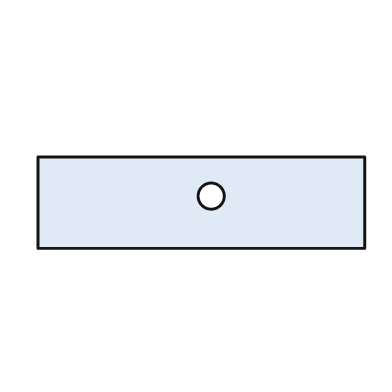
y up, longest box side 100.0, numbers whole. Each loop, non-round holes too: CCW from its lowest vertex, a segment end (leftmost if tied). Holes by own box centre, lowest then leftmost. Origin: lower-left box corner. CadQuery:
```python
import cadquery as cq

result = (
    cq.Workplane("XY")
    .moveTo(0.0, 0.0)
    .lineTo(100.0, 0.0)
    .lineTo(100.0, 28.0)
    .lineTo(0.0, 28.0)
    .close()
    .moveTo(53.0, 16.0)
    .circle(4.0)
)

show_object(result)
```